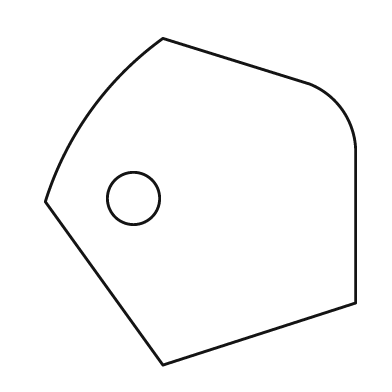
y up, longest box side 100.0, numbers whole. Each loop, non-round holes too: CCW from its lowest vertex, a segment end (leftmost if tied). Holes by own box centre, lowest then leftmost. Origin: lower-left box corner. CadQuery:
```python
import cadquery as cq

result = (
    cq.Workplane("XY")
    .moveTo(36.0, 0.0)
    .lineTo(95.0, 19.0)
    .lineTo(95.0, 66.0)
    .threePointArc((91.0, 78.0), (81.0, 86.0))
    .lineTo(36.0, 100.0)
    .threePointArc((14.0, 78.0), (0.0, 50.0))
    .close()
    .moveTo(27.0, 51.0)
    .circle(8.0)
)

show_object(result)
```